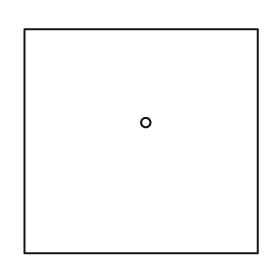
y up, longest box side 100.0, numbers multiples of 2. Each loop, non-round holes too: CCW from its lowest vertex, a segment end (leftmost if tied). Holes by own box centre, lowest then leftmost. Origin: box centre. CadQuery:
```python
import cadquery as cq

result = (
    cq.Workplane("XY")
    .moveTo(-50.0, -48.0)
    .lineTo(50.0, -48.0)
    .lineTo(50.0, 48.0)
    .lineTo(-50.0, 48.0)
    .close()
    .moveTo(2.0, 8.0)
    .circle(2.0)
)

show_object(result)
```